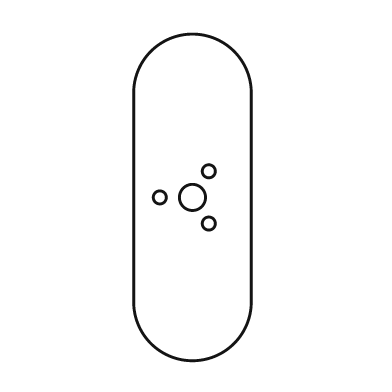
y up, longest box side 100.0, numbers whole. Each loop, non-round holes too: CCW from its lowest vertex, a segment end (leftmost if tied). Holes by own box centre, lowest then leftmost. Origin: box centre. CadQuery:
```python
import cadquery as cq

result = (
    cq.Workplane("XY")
    .moveTo(-18.0, -32.0)
    .threePointArc((0.0, -50.0), (18.0, -32.0))
    .lineTo(18.0, 32.0)
    .threePointArc((0.0, 50.0), (-18.0, 32.0))
    .close()
    .moveTo(5.0, -8.0)
    .circle(2.0)
    .moveTo(-10.0, 0.0)
    .circle(2.0)
    .moveTo(0.0, 0.0)
    .circle(4.0)
    .moveTo(5.0, 8.0)
    .circle(2.0)
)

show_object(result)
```